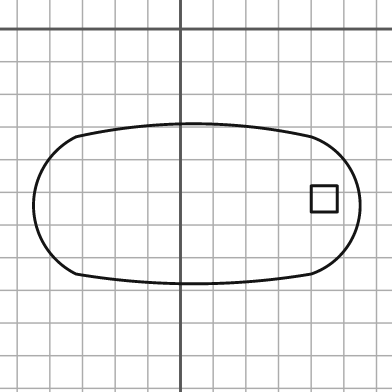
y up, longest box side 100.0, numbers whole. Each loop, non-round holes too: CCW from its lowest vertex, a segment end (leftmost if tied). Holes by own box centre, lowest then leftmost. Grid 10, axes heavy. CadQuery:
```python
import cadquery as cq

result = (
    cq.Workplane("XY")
    .moveTo(-32.0, -75.0)
    .threePointArc((4.0, -78.0), (40.0, -75.0))
    .threePointArc((55.0, -54.0), (40.0, -33.0))
    .threePointArc((4.0, -29.0), (-32.0, -33.0))
    .threePointArc((-45.0, -54.0), (-32.0, -75.0))
    .close()
    .moveTo(40.0, -56.0)
    .lineTo(48.0, -56.0)
    .lineTo(48.0, -48.0)
    .lineTo(40.0, -48.0)
    .close()
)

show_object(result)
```